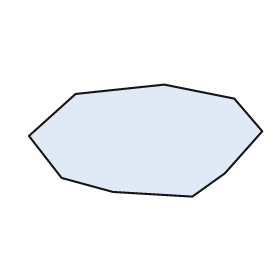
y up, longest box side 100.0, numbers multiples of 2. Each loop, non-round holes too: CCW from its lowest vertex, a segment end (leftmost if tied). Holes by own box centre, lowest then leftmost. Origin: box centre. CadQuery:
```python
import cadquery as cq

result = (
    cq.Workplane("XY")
    .moveTo(20.0, -24.0)
    .lineTo(34.0, -14.0)
    .lineTo(50.0, 4.0)
    .lineTo(38.0, 18.0)
    .lineTo(8.0, 24.0)
    .lineTo(-30.0, 20.0)
    .lineTo(-50.0, 2.0)
    .lineTo(-36.0, -16.0)
    .lineTo(-14.0, -22.0)
    .close()
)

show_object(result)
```